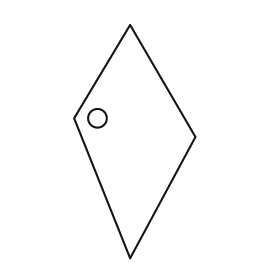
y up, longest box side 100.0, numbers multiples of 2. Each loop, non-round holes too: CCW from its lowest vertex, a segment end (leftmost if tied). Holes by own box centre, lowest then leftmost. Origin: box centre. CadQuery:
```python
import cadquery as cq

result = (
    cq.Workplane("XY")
    .moveTo(-2.0, -50.0)
    .lineTo(26.0, 2.0)
    .lineTo(-2.0, 50.0)
    .lineTo(-26.0, 10.0)
    .close()
    .moveTo(-16.0, 10.0)
    .circle(4.0)
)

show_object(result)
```